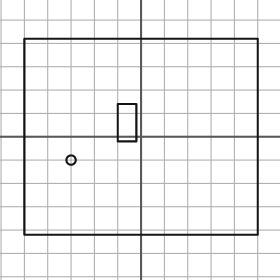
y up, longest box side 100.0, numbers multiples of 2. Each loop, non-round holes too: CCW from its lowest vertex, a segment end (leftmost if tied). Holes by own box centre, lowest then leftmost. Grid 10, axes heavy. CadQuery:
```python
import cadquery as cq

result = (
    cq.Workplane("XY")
    .moveTo(-50.0, -42.0)
    .lineTo(50.0, -42.0)
    .lineTo(50.0, 42.0)
    .lineTo(-50.0, 42.0)
    .close()
    .moveTo(-30.0, -10.0)
    .circle(2.0)
    .moveTo(-10.0, -2.0)
    .lineTo(-2.0, -2.0)
    .lineTo(-2.0, 14.0)
    .lineTo(-10.0, 14.0)
    .close()
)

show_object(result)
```